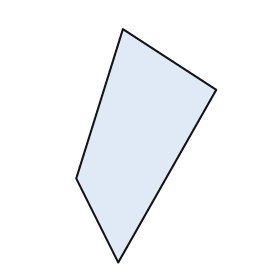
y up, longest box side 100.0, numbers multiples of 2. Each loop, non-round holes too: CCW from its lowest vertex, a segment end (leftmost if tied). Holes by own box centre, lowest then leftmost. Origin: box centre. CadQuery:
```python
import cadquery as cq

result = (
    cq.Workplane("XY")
    .moveTo(-12.0, -50.0)
    .lineTo(30.0, 24.0)
    .lineTo(-10.0, 50.0)
    .lineTo(-30.0, -14.0)
    .close()
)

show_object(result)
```